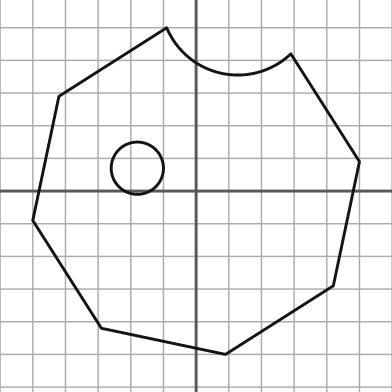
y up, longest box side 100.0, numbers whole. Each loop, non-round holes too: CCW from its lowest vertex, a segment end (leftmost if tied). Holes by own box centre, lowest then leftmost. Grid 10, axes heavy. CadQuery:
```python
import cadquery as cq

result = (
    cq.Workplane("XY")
    .moveTo(9.0, -50.0)
    .lineTo(42.0, -29.0)
    .lineTo(50.0, 9.0)
    .lineTo(29.0, 42.0)
    .threePointArc((8.0, 36.0), (-9.0, 50.0))
    .lineTo(-42.0, 29.0)
    .lineTo(-50.0, -9.0)
    .lineTo(-29.0, -42.0)
    .close()
    .moveTo(-18.0, 7.0)
    .circle(8.0)
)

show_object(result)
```